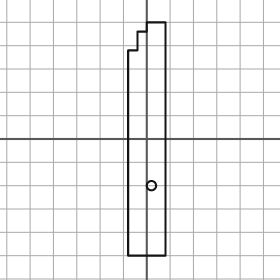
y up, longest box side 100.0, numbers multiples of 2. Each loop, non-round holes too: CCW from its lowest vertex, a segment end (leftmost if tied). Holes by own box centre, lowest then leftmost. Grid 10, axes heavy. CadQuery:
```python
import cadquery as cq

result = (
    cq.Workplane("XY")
    .moveTo(-8.0, -50.0)
    .lineTo(8.0, -50.0)
    .lineTo(8.0, 50.0)
    .lineTo(0.0, 50.0)
    .lineTo(0.0, 46.0)
    .lineTo(-4.0, 46.0)
    .lineTo(-4.0, 38.0)
    .lineTo(-8.0, 38.0)
    .close()
    .moveTo(2.0, -20.0)
    .circle(2.0)
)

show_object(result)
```